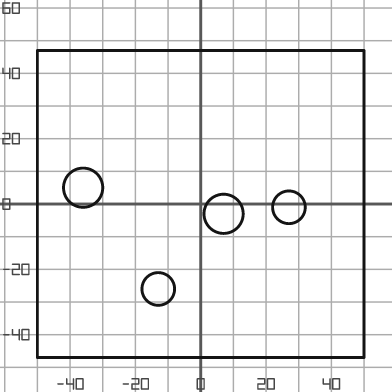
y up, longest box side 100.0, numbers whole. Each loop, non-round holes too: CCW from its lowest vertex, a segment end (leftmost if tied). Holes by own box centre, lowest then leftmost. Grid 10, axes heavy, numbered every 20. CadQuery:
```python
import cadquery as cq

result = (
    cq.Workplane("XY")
    .moveTo(-50.0, -47.0)
    .lineTo(50.0, -47.0)
    .lineTo(50.0, 47.0)
    .lineTo(-50.0, 47.0)
    .close()
    .moveTo(-13.0, -26.0)
    .circle(5.0)
    .moveTo(7.0, -3.0)
    .circle(6.0)
    .moveTo(27.0, -1.0)
    .circle(5.0)
    .moveTo(-36.0, 5.0)
    .circle(6.0)
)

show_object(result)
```